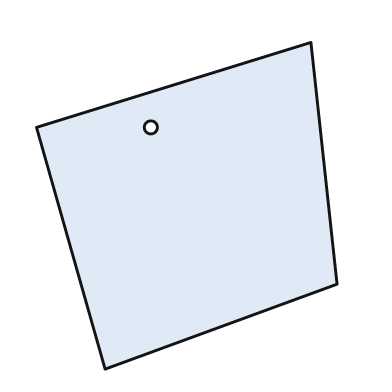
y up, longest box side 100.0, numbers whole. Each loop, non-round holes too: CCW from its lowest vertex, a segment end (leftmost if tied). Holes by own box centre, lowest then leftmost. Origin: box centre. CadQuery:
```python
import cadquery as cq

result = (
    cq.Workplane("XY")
    .moveTo(-25.0, -50.0)
    .lineTo(46.0, -24.0)
    .lineTo(38.0, 50.0)
    .lineTo(-46.0, 24.0)
    .close()
    .moveTo(-11.0, 24.0)
    .circle(2.0)
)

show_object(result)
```